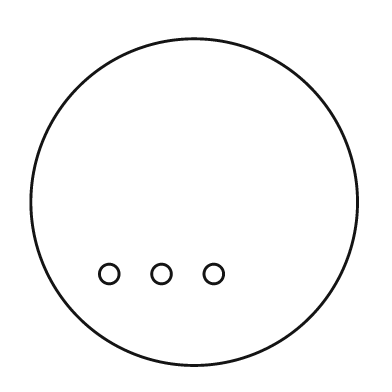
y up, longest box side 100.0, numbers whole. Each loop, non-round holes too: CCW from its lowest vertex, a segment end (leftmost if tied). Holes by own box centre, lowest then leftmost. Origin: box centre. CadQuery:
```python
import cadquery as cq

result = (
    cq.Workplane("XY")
    .moveTo(0.0, 0.0)
    .circle(50.0)
    .moveTo(-26.0, -22.0)
    .circle(3.0)
    .moveTo(-10.0, -22.0)
    .circle(3.0)
    .moveTo(6.0, -22.0)
    .circle(3.0)
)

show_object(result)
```